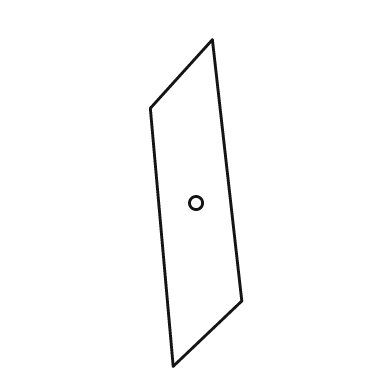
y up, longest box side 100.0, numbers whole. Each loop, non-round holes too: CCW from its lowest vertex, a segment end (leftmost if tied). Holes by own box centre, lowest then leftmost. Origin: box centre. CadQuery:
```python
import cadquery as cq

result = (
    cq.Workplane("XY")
    .moveTo(-7.0, -50.0)
    .lineTo(14.0, -30.0)
    .lineTo(5.0, 50.0)
    .lineTo(-14.0, 29.0)
    .close()
    .moveTo(0.0, 0.0)
    .circle(2.0)
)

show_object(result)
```